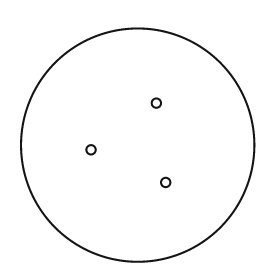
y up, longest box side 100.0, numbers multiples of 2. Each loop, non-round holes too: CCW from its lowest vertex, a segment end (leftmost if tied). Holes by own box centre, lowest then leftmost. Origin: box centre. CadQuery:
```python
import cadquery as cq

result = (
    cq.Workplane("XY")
    .moveTo(0.0, 0.0)
    .circle(50.0)
    .moveTo(12.0, -16.0)
    .circle(2.0)
    .moveTo(-20.0, -2.0)
    .circle(2.0)
    .moveTo(8.0, 18.0)
    .circle(2.0)
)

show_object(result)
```